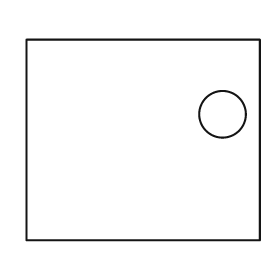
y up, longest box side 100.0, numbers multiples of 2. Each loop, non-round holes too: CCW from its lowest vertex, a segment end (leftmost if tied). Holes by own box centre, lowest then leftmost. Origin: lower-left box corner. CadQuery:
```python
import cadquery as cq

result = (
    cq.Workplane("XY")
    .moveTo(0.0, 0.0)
    .lineTo(100.0, 0.0)
    .lineTo(100.0, 86.0)
    .lineTo(0.0, 86.0)
    .close()
    .moveTo(84.0, 54.0)
    .circle(10.0)
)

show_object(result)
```